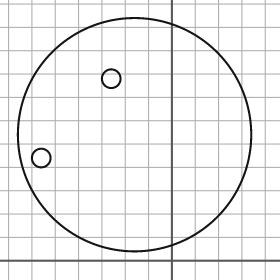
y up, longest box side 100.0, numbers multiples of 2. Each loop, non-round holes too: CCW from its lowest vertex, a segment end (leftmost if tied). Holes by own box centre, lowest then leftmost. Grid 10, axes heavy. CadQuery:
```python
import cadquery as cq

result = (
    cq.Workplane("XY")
    .moveTo(-16.0, 54.0)
    .circle(50.0)
    .moveTo(-56.0, 44.0)
    .circle(4.0)
    .moveTo(-26.0, 78.0)
    .circle(4.0)
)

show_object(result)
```